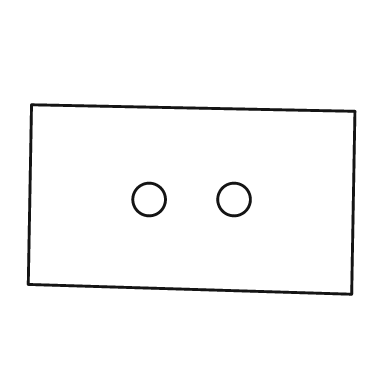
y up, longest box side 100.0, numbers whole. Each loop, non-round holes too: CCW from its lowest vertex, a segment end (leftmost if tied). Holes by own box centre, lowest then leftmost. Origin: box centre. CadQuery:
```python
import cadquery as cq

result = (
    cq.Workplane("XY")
    .moveTo(49.0, -29.0)
    .lineTo(50.0, 27.0)
    .lineTo(-49.0, 29.0)
    .lineTo(-50.0, -26.0)
    .close()
    .moveTo(-13.0, 0.0)
    .circle(5.0)
    .moveTo(13.0, 0.0)
    .circle(5.0)
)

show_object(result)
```